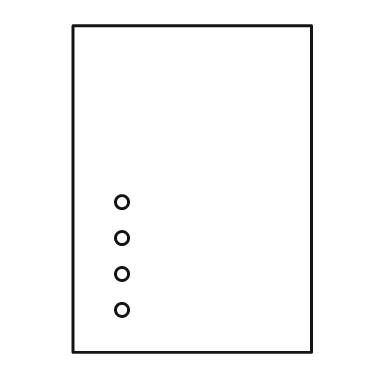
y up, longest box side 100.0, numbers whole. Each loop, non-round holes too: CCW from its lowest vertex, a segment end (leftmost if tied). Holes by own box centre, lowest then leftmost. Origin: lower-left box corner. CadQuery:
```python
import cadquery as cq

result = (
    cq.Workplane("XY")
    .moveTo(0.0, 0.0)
    .lineTo(73.0, 0.0)
    .lineTo(73.0, 100.0)
    .lineTo(0.0, 100.0)
    .close()
    .moveTo(15.0, 13.0)
    .circle(2.0)
    .moveTo(15.0, 24.0)
    .circle(2.0)
    .moveTo(15.0, 35.0)
    .circle(2.0)
    .moveTo(15.0, 46.0)
    .circle(2.0)
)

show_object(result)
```